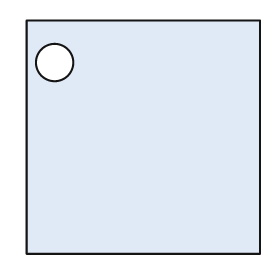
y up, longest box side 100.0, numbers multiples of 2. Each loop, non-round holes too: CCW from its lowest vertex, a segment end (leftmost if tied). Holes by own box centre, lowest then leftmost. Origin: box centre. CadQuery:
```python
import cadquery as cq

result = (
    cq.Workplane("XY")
    .moveTo(-50.0, -50.0)
    .lineTo(50.0, -50.0)
    .lineTo(50.0, 50.0)
    .lineTo(-50.0, 50.0)
    .close()
    .moveTo(-38.0, 32.0)
    .circle(8.0)
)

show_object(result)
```